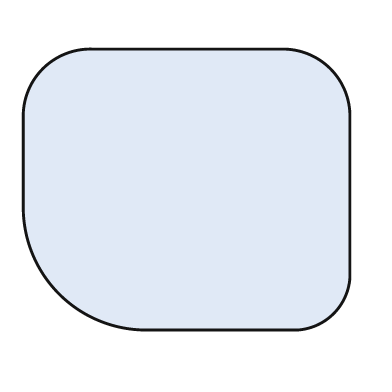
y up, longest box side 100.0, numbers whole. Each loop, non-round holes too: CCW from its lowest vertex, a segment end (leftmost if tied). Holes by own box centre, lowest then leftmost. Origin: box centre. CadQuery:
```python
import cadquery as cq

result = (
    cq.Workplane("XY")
    .moveTo(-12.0, -43.0)
    .lineTo(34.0, -43.0)
    .threePointArc((45.0, -38.0), (50.0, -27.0))
    .lineTo(50.0, 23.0)
    .threePointArc((44.0, 37.0), (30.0, 43.0))
    .lineTo(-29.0, 43.0)
    .threePointArc((-44.0, 37.0), (-50.0, 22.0))
    .lineTo(-50.0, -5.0)
    .threePointArc((-39.0, -32.0), (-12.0, -43.0))
    .close()
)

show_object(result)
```